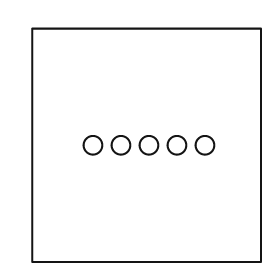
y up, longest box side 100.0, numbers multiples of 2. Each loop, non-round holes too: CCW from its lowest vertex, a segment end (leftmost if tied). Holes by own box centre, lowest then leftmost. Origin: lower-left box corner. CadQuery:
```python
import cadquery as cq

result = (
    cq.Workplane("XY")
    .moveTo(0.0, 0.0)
    .lineTo(98.0, 0.0)
    .lineTo(98.0, 100.0)
    .lineTo(0.0, 100.0)
    .close()
    .moveTo(26.0, 50.0)
    .circle(4.0)
    .moveTo(38.0, 50.0)
    .circle(4.0)
    .moveTo(50.0, 50.0)
    .circle(4.0)
    .moveTo(62.0, 50.0)
    .circle(4.0)
    .moveTo(74.0, 50.0)
    .circle(4.0)
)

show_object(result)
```